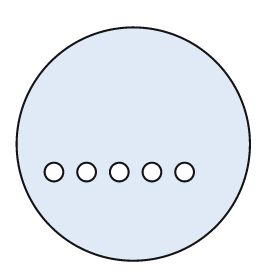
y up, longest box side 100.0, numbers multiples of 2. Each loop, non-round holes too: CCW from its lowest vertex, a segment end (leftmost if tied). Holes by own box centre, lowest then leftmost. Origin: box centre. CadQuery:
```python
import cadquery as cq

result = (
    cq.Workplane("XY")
    .moveTo(0.0, 0.0)
    .circle(50.0)
    .moveTo(-34.0, -12.0)
    .circle(4.0)
    .moveTo(-20.0, -12.0)
    .circle(4.0)
    .moveTo(-6.0, -12.0)
    .circle(4.0)
    .moveTo(8.0, -12.0)
    .circle(4.0)
    .moveTo(22.0, -12.0)
    .circle(4.0)
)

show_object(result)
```